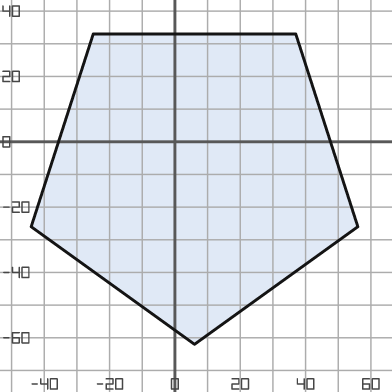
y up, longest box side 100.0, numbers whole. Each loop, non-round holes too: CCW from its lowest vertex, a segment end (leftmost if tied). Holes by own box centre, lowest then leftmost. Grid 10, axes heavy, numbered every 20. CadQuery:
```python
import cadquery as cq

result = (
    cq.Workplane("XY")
    .moveTo(6.0, -62.0)
    .lineTo(56.0, -26.0)
    .lineTo(37.0, 33.0)
    .lineTo(-25.0, 33.0)
    .lineTo(-44.0, -26.0)
    .close()
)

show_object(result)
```